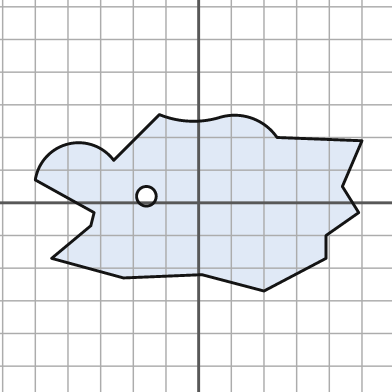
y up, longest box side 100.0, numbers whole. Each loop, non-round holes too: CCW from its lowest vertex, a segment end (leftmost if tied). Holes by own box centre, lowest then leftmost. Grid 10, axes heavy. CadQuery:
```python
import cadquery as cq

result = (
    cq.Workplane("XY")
    .moveTo(20.0, -27.0)
    .lineTo(39.0, -17.0)
    .lineTo(39.0, -10.0)
    .lineTo(49.0, -3.0)
    .lineTo(44.0, 5.0)
    .lineTo(50.0, 19.0)
    .lineTo(24.0, 20.0)
    .threePointArc((16.0, 26.0), (6.0, 26.0))
    .threePointArc((-3.0, 25.0), (-12.0, 27.0))
    .lineTo(-26.0, 13.0)
    .threePointArc((-40.0, 18.0), (-50.0, 7.0))
    .lineTo(-32.0, -3.0)
    .lineTo(-33.0, -7.0)
    .lineTo(-45.0, -17.0)
    .lineTo(-23.0, -23.0)
    .lineTo(1.0, -22.0)
    .close()
    .moveTo(-16.0, 2.0)
    .circle(3.0)
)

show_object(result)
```